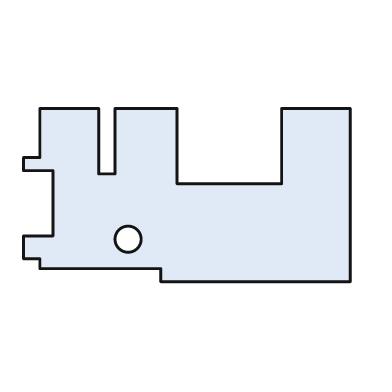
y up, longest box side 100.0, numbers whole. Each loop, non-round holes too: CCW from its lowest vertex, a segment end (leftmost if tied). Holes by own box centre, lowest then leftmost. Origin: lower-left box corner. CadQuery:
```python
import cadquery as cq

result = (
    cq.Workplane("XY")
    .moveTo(42.0, 0.0)
    .lineTo(100.0, 0.0)
    .lineTo(100.0, 53.0)
    .lineTo(79.0, 53.0)
    .lineTo(79.0, 30.0)
    .lineTo(47.0, 30.0)
    .lineTo(47.0, 53.0)
    .lineTo(28.0, 53.0)
    .lineTo(28.0, 33.0)
    .lineTo(23.0, 33.0)
    .lineTo(23.0, 53.0)
    .lineTo(5.0, 53.0)
    .lineTo(5.0, 38.0)
    .lineTo(0.0, 38.0)
    .lineTo(0.0, 34.0)
    .lineTo(9.0, 34.0)
    .lineTo(9.0, 14.0)
    .lineTo(0.0, 14.0)
    .lineTo(0.0, 7.0)
    .lineTo(5.0, 7.0)
    .lineTo(5.0, 4.0)
    .lineTo(42.0, 4.0)
    .close()
    .moveTo(32.0, 13.0)
    .circle(4.0)
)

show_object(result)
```